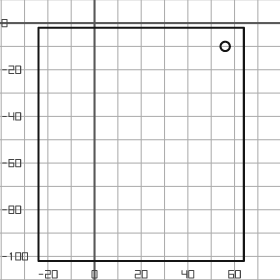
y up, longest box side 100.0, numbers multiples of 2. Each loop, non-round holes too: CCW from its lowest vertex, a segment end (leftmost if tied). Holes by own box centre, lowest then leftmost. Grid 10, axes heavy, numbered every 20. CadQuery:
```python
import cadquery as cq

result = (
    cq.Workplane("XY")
    .moveTo(-24.0, -102.0)
    .lineTo(64.0, -102.0)
    .lineTo(64.0, -2.0)
    .lineTo(-24.0, -2.0)
    .close()
    .moveTo(56.0, -10.0)
    .circle(2.0)
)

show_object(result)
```